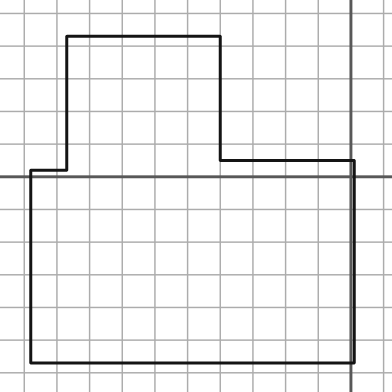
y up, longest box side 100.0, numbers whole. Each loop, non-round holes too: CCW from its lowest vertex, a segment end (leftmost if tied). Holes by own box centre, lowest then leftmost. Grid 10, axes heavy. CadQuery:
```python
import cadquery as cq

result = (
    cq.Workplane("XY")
    .moveTo(-98.0, -57.0)
    .lineTo(1.0, -57.0)
    .lineTo(1.0, 5.0)
    .lineTo(-40.0, 5.0)
    .lineTo(-40.0, 43.0)
    .lineTo(-87.0, 43.0)
    .lineTo(-87.0, 2.0)
    .lineTo(-98.0, 2.0)
    .close()
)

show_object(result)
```